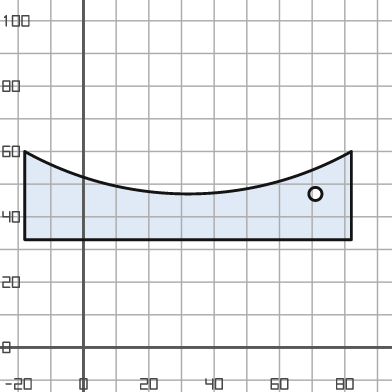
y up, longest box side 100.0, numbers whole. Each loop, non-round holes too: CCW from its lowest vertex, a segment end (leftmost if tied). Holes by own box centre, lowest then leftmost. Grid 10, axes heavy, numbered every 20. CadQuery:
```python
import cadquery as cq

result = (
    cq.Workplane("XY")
    .moveTo(-18.0, 33.0)
    .lineTo(82.0, 33.0)
    .lineTo(82.0, 60.0)
    .threePointArc((32.0, 47.0), (-18.0, 60.0))
    .close()
    .moveTo(71.0, 47.0)
    .circle(2.0)
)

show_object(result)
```